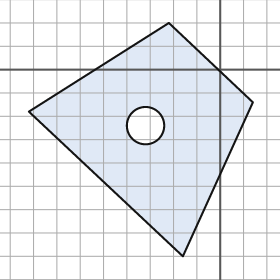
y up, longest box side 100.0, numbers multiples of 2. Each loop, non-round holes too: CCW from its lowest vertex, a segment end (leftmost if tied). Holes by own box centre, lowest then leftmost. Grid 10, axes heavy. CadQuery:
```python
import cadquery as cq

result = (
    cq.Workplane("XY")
    .moveTo(-16.0, -80.0)
    .lineTo(14.0, -14.0)
    .lineTo(-22.0, 20.0)
    .lineTo(-82.0, -18.0)
    .close()
    .moveTo(-32.0, -24.0)
    .circle(8.0)
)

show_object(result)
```